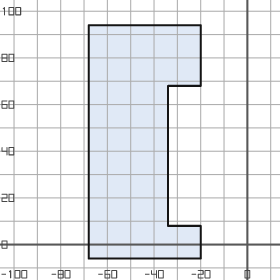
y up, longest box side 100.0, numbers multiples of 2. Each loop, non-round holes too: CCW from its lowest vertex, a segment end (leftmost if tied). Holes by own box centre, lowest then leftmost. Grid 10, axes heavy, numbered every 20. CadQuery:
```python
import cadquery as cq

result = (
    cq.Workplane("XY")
    .moveTo(-68.0, -6.0)
    .lineTo(-20.0, -6.0)
    .lineTo(-20.0, 8.0)
    .lineTo(-34.0, 8.0)
    .lineTo(-34.0, 68.0)
    .lineTo(-20.0, 68.0)
    .lineTo(-20.0, 94.0)
    .lineTo(-68.0, 94.0)
    .close()
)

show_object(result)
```